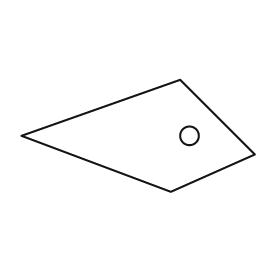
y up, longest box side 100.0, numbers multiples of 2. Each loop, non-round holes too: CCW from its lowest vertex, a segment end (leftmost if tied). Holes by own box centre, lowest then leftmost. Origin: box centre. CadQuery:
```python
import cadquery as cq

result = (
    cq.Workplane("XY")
    .moveTo(14.0, -24.0)
    .lineTo(50.0, -8.0)
    .lineTo(18.0, 24.0)
    .lineTo(-50.0, 0.0)
    .close()
    .moveTo(22.0, 0.0)
    .circle(4.0)
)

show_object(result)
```